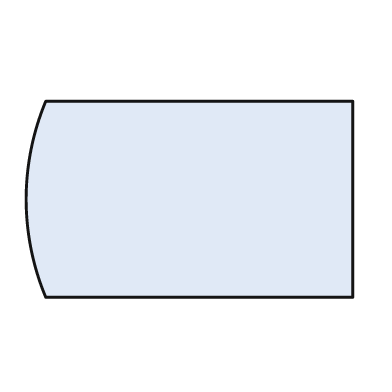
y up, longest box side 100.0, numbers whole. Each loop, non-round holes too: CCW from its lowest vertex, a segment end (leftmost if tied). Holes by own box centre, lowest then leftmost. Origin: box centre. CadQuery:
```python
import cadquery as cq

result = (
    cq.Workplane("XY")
    .moveTo(-44.0, -30.0)
    .lineTo(50.0, -30.0)
    .lineTo(50.0, 30.0)
    .lineTo(-44.0, 30.0)
    .threePointArc((-50.0, 0.0), (-44.0, -30.0))
    .close()
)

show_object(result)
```